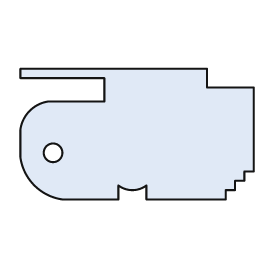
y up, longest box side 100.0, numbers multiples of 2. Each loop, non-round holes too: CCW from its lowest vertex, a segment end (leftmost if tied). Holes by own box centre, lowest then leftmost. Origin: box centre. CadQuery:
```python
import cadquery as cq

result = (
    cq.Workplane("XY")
    .moveTo(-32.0, -28.0)
    .lineTo(-8.0, -28.0)
    .lineTo(-8.0, -22.0)
    .threePointArc((-2.0, -24.0), (4.0, -22.0))
    .lineTo(4.0, -28.0)
    .lineTo(38.0, -28.0)
    .lineTo(38.0, -24.0)
    .lineTo(42.0, -24.0)
    .lineTo(42.0, -20.0)
    .lineTo(46.0, -20.0)
    .lineTo(46.0, -16.0)
    .lineTo(50.0, -16.0)
    .lineTo(50.0, 20.0)
    .lineTo(30.0, 20.0)
    .lineTo(30.0, 28.0)
    .lineTo(-50.0, 28.0)
    .lineTo(-50.0, 24.0)
    .lineTo(-14.0, 24.0)
    .lineTo(-14.0, 14.0)
    .lineTo(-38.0, 14.0)
    .threePointArc((-46.0, 10.0), (-50.0, 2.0))
    .lineTo(-50.0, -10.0)
    .threePointArc((-44.0, -22.0), (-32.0, -28.0))
    .close()
    .moveTo(-36.0, -8.0)
    .circle(4.0)
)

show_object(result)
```